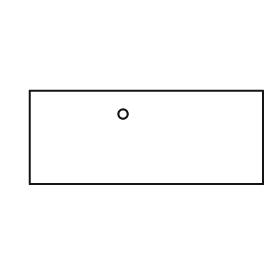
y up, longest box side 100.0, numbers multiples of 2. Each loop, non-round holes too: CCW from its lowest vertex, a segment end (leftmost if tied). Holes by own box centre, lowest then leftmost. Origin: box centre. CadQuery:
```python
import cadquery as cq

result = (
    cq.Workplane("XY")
    .moveTo(-50.0, -20.0)
    .lineTo(50.0, -20.0)
    .lineTo(50.0, 20.0)
    .lineTo(-50.0, 20.0)
    .close()
    .moveTo(-10.0, 10.0)
    .circle(2.0)
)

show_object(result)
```